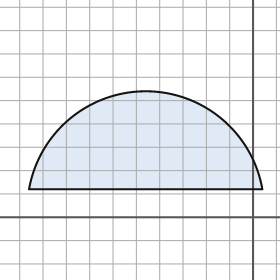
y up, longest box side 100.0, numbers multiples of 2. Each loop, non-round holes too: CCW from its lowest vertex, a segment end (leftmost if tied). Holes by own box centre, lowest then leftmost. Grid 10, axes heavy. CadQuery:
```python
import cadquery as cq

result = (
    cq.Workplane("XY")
    .moveTo(-96.0, 12.0)
    .lineTo(4.0, 12.0)
    .threePointArc((-46.0, 54.0), (-96.0, 12.0))
    .close()
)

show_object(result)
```